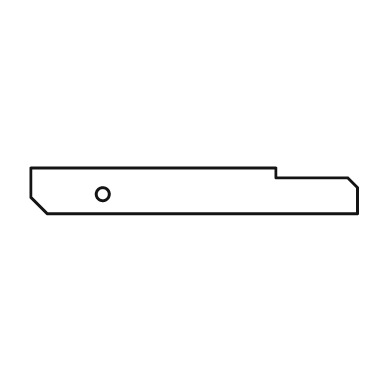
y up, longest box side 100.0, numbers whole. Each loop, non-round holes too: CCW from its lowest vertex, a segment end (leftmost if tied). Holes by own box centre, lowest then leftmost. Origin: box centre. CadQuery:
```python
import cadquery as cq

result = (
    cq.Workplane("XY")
    .moveTo(-45.0, -7.0)
    .lineTo(50.0, -7.0)
    .lineTo(50.0, 1.0)
    .lineTo(47.0, 4.0)
    .lineTo(25.0, 4.0)
    .lineTo(25.0, 7.0)
    .lineTo(-50.0, 7.0)
    .lineTo(-50.0, -2.0)
    .close()
    .moveTo(-28.0, -1.0)
    .circle(2.0)
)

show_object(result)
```